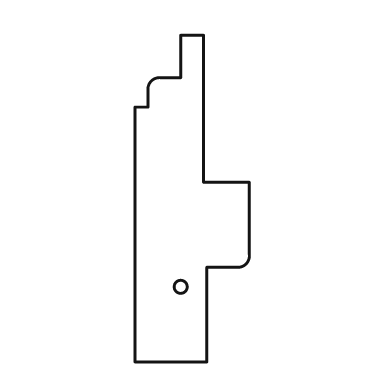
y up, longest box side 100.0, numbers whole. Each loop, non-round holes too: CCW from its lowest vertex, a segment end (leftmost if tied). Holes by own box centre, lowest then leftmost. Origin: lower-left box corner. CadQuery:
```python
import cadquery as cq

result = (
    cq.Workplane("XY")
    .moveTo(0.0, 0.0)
    .lineTo(22.0, 0.0)
    .lineTo(22.0, 29.0)
    .lineTo(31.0, 29.0)
    .threePointArc((34.0, 30.0), (35.0, 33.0))
    .lineTo(35.0, 55.0)
    .lineTo(21.0, 55.0)
    .lineTo(21.0, 100.0)
    .lineTo(14.0, 100.0)
    .lineTo(14.0, 87.0)
    .lineTo(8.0, 87.0)
    .threePointArc((5.0, 86.0), (4.0, 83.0))
    .lineTo(4.0, 78.0)
    .lineTo(0.0, 78.0)
    .close()
    .moveTo(14.0, 23.0)
    .circle(2.0)
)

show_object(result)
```